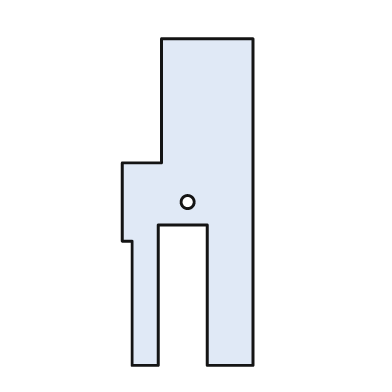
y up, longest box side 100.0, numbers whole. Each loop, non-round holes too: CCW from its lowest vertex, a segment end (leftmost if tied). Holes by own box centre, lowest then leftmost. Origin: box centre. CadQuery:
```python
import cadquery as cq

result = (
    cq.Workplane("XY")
    .moveTo(-17.0, -50.0)
    .lineTo(-9.0, -50.0)
    .lineTo(-9.0, -7.0)
    .lineTo(6.0, -7.0)
    .lineTo(6.0, -50.0)
    .lineTo(20.0, -50.0)
    .lineTo(20.0, 50.0)
    .lineTo(-8.0, 50.0)
    .lineTo(-8.0, 12.0)
    .lineTo(-20.0, 12.0)
    .lineTo(-20.0, -12.0)
    .lineTo(-17.0, -12.0)
    .close()
    .moveTo(0.0, 0.0)
    .circle(2.0)
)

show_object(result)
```